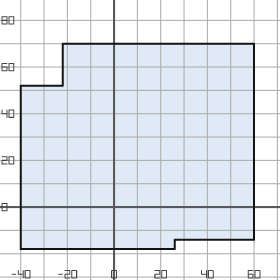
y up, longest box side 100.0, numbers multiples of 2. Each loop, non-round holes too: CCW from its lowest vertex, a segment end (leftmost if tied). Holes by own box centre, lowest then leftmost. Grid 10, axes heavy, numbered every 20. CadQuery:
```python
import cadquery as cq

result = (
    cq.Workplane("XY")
    .moveTo(-40.0, -18.0)
    .lineTo(26.0, -18.0)
    .lineTo(26.0, -14.0)
    .lineTo(60.0, -14.0)
    .lineTo(60.0, 70.0)
    .lineTo(-22.0, 70.0)
    .lineTo(-22.0, 52.0)
    .lineTo(-40.0, 52.0)
    .close()
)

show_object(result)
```